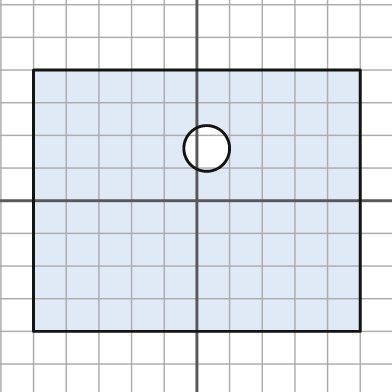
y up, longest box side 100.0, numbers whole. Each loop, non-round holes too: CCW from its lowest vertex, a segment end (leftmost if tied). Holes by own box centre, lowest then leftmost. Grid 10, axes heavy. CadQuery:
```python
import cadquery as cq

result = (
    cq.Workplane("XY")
    .moveTo(-50.0, -40.0)
    .lineTo(50.0, -40.0)
    .lineTo(50.0, 40.0)
    .lineTo(-50.0, 40.0)
    .close()
    .moveTo(3.0, 16.0)
    .circle(7.0)
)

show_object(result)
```